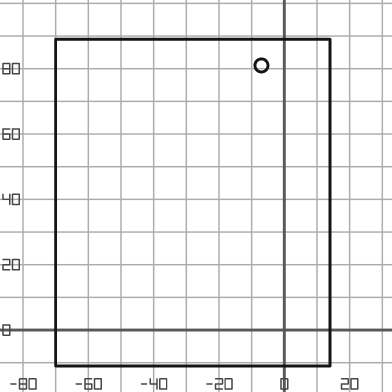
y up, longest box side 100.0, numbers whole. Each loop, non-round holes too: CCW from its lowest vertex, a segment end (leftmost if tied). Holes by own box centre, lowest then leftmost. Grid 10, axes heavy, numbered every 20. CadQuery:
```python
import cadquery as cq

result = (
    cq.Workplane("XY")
    .moveTo(-70.0, -11.0)
    .lineTo(14.0, -11.0)
    .lineTo(14.0, 89.0)
    .lineTo(-70.0, 89.0)
    .close()
    .moveTo(-7.0, 81.0)
    .circle(2.0)
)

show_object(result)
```